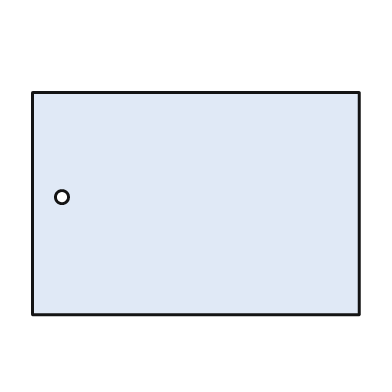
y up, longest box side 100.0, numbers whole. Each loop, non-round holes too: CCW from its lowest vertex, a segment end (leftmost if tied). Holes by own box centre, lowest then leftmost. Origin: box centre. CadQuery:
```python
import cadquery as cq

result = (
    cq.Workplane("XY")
    .moveTo(-50.0, -34.0)
    .lineTo(50.0, -34.0)
    .lineTo(50.0, 34.0)
    .lineTo(-50.0, 34.0)
    .close()
    .moveTo(-41.0, 2.0)
    .circle(2.0)
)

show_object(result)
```